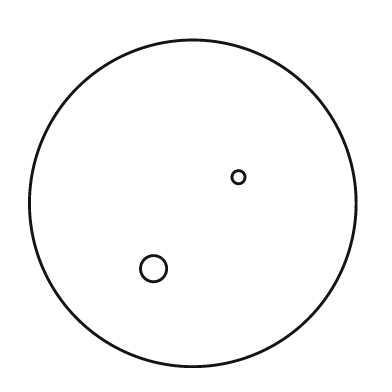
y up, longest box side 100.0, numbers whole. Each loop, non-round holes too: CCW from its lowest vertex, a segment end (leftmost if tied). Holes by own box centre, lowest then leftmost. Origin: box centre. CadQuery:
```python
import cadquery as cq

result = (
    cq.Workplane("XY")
    .moveTo(0.0, 0.0)
    .circle(50.0)
    .moveTo(-12.0, -20.0)
    .circle(4.0)
    .moveTo(14.0, 8.0)
    .circle(2.0)
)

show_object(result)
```